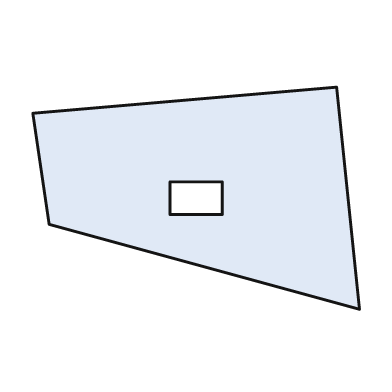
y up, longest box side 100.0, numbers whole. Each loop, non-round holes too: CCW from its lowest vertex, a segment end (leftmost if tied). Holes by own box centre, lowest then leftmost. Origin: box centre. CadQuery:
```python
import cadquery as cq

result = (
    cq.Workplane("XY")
    .moveTo(50.0, -34.0)
    .lineTo(43.0, 34.0)
    .lineTo(-50.0, 26.0)
    .lineTo(-45.0, -8.0)
    .close()
    .moveTo(-8.0, -5.0)
    .lineTo(8.0, -5.0)
    .lineTo(8.0, 5.0)
    .lineTo(-8.0, 5.0)
    .close()
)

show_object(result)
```